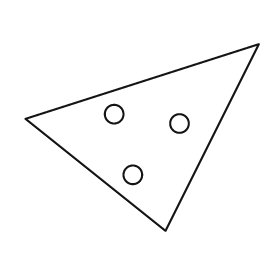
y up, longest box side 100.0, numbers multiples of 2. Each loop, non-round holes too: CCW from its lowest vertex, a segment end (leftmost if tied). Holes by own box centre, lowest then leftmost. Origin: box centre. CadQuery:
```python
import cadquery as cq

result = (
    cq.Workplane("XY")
    .moveTo(10.0, -40.0)
    .lineTo(50.0, 40.0)
    .lineTo(-50.0, 8.0)
    .close()
    .moveTo(-4.0, -16.0)
    .circle(4.0)
    .moveTo(16.0, 6.0)
    .circle(4.0)
    .moveTo(-12.0, 10.0)
    .circle(4.0)
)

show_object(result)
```